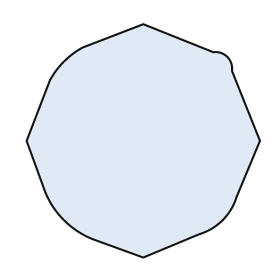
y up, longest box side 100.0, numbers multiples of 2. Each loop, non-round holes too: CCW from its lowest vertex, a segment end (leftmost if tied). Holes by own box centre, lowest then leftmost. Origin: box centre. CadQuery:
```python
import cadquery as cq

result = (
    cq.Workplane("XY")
    .moveTo(0.0, -50.0)
    .lineTo(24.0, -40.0)
    .threePointArc((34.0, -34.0), (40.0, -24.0))
    .lineTo(50.0, 0.0)
    .lineTo(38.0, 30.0)
    .threePointArc((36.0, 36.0), (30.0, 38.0))
    .lineTo(0.0, 50.0)
    .lineTo(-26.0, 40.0)
    .threePointArc((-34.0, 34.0), (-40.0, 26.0))
    .lineTo(-50.0, 0.0)
    .lineTo(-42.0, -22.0)
    .threePointArc((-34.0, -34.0), (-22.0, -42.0))
    .close()
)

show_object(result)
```